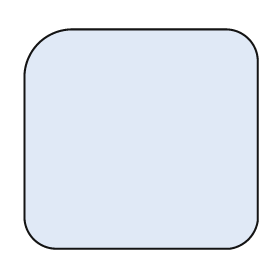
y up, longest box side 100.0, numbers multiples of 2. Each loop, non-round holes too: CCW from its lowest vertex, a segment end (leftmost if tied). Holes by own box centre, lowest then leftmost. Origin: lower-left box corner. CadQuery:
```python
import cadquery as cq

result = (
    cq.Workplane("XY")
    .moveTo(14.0, 0.0)
    .lineTo(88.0, 0.0)
    .threePointArc((96.0, 4.0), (100.0, 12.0))
    .lineTo(100.0, 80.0)
    .threePointArc((96.0, 90.0), (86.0, 94.0))
    .lineTo(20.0, 94.0)
    .threePointArc((6.0, 88.0), (0.0, 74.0))
    .lineTo(0.0, 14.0)
    .threePointArc((4.0, 4.0), (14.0, 0.0))
    .close()
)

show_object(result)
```